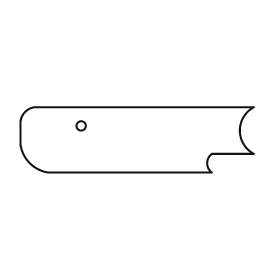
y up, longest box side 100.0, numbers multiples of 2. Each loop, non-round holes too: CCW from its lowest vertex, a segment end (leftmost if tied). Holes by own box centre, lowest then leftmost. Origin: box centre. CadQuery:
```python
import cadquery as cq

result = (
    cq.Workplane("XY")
    .moveTo(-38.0, -14.0)
    .lineTo(32.0, -14.0)
    .threePointArc((30.0, -10.0), (32.0, -6.0))
    .lineTo(50.0, -6.0)
    .threePointArc((44.0, 4.0), (50.0, 14.0))
    .lineTo(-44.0, 14.0)
    .threePointArc((-48.0, 12.0), (-50.0, 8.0))
    .lineTo(-50.0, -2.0)
    .threePointArc((-46.0, -10.0), (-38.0, -14.0))
    .close()
    .moveTo(-24.0, 6.0)
    .circle(2.0)
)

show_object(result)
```